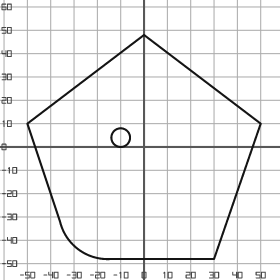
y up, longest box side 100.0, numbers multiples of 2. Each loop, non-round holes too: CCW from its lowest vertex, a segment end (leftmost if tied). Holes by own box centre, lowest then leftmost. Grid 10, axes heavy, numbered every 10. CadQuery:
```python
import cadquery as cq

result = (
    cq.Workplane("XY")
    .moveTo(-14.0, -48.0)
    .lineTo(30.0, -48.0)
    .lineTo(50.0, 10.0)
    .lineTo(0.0, 48.0)
    .lineTo(-50.0, 10.0)
    .lineTo(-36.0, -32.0)
    .threePointArc((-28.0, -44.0), (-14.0, -48.0))
    .close()
    .moveTo(-10.0, 4.0)
    .circle(4.0)
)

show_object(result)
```